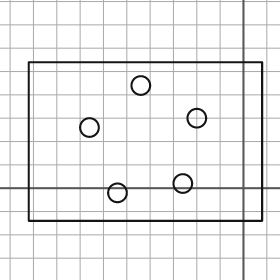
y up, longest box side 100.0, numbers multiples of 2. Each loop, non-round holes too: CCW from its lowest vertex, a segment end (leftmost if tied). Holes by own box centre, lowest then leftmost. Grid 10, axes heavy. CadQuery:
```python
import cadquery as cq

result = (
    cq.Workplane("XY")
    .moveTo(-92.0, -14.0)
    .lineTo(8.0, -14.0)
    .lineTo(8.0, 54.0)
    .lineTo(-92.0, 54.0)
    .close()
    .moveTo(-54.0, -2.0)
    .circle(4.0)
    .moveTo(-26.0, 2.0)
    .circle(4.0)
    .moveTo(-66.0, 26.0)
    .circle(4.0)
    .moveTo(-20.0, 30.0)
    .circle(4.0)
    .moveTo(-44.0, 44.0)
    .circle(4.0)
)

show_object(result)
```